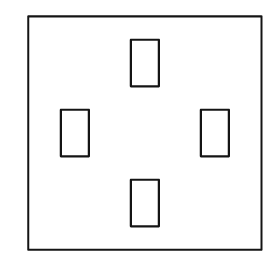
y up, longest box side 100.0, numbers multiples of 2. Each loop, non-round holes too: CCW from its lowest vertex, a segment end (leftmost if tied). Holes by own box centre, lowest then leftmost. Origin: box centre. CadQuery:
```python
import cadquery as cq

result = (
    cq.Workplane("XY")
    .moveTo(-50.0, -50.0)
    .lineTo(50.0, -50.0)
    .lineTo(50.0, 50.0)
    .lineTo(-50.0, 50.0)
    .close()
    .moveTo(-6.0, -40.0)
    .lineTo(6.0, -40.0)
    .lineTo(6.0, -20.0)
    .lineTo(-6.0, -20.0)
    .close()
    .moveTo(-36.0, -10.0)
    .lineTo(-24.0, -10.0)
    .lineTo(-24.0, 10.0)
    .lineTo(-36.0, 10.0)
    .close()
    .moveTo(24.0, -10.0)
    .lineTo(36.0, -10.0)
    .lineTo(36.0, 10.0)
    .lineTo(24.0, 10.0)
    .close()
    .moveTo(-6.0, 20.0)
    .lineTo(6.0, 20.0)
    .lineTo(6.0, 40.0)
    .lineTo(-6.0, 40.0)
    .close()
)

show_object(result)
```